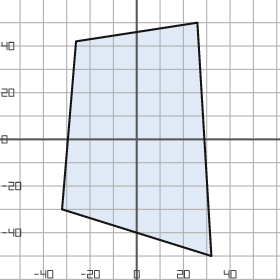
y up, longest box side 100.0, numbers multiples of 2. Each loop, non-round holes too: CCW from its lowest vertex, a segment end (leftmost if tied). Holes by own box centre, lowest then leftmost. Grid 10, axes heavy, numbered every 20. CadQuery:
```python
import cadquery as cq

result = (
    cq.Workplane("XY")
    .moveTo(32.0, -50.0)
    .lineTo(26.0, 50.0)
    .lineTo(-26.0, 42.0)
    .lineTo(-32.0, -30.0)
    .close()
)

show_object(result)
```